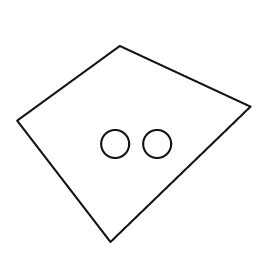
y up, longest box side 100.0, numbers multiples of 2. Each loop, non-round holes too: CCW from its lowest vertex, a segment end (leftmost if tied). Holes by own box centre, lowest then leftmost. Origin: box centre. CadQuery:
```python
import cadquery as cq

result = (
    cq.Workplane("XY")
    .moveTo(-10.0, -42.0)
    .lineTo(50.0, 16.0)
    .lineTo(-6.0, 42.0)
    .lineTo(-50.0, 10.0)
    .close()
    .moveTo(-8.0, 0.0)
    .circle(6.0)
    .moveTo(10.0, 0.0)
    .circle(6.0)
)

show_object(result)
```